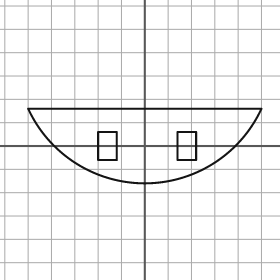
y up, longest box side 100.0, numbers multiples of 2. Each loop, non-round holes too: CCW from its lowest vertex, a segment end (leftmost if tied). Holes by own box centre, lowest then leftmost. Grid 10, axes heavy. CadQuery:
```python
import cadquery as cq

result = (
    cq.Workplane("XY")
    .moveTo(-50.0, 16.0)
    .threePointArc((0.0, -16.0), (50.0, 16.0))
    .close()
    .moveTo(-20.0, -6.0)
    .lineTo(-12.0, -6.0)
    .lineTo(-12.0, 6.0)
    .lineTo(-20.0, 6.0)
    .close()
    .moveTo(14.0, -6.0)
    .lineTo(22.0, -6.0)
    .lineTo(22.0, 6.0)
    .lineTo(14.0, 6.0)
    .close()
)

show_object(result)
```